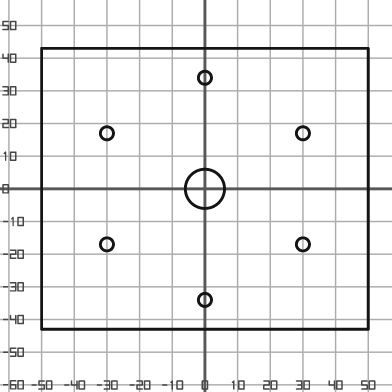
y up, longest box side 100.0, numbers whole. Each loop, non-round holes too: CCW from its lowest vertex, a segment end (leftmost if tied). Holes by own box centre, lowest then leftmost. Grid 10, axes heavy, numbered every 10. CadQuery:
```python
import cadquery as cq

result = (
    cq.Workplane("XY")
    .moveTo(-50.0, -43.0)
    .lineTo(50.0, -43.0)
    .lineTo(50.0, 43.0)
    .lineTo(-50.0, 43.0)
    .close()
    .moveTo(0.0, -34.0)
    .circle(2.0)
    .moveTo(-30.0, -17.0)
    .circle(2.0)
    .moveTo(30.0, -17.0)
    .circle(2.0)
    .moveTo(0.0, 0.0)
    .circle(6.0)
    .moveTo(-30.0, 17.0)
    .circle(2.0)
    .moveTo(30.0, 17.0)
    .circle(2.0)
    .moveTo(0.0, 34.0)
    .circle(2.0)
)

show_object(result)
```